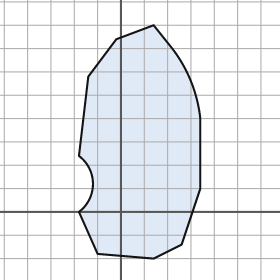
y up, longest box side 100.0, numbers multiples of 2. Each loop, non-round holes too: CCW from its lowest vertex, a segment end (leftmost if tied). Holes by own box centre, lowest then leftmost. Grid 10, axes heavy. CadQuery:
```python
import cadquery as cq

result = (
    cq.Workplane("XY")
    .moveTo(14.0, -20.0)
    .lineTo(26.0, -14.0)
    .lineTo(34.0, 10.0)
    .lineTo(34.0, 40.0)
    .threePointArc((30.0, 56.0), (22.0, 70.0))
    .lineTo(14.0, 80.0)
    .lineTo(-2.0, 74.0)
    .lineTo(-14.0, 58.0)
    .lineTo(-18.0, 24.0)
    .threePointArc((-12.0, 12.0), (-18.0, 0.0))
    .lineTo(-10.0, -18.0)
    .close()
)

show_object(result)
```